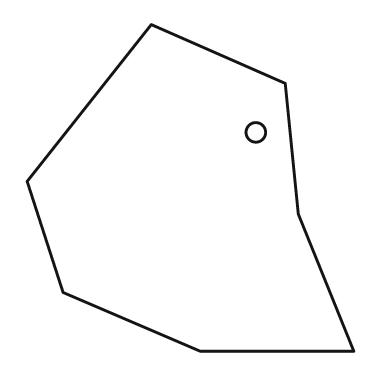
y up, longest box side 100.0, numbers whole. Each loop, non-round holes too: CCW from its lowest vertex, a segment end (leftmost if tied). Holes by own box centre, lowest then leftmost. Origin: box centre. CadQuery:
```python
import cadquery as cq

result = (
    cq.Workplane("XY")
    .moveTo(3.0, -50.0)
    .lineTo(50.0, -50.0)
    .lineTo(33.0, -8.0)
    .lineTo(29.0, 32.0)
    .lineTo(-12.0, 50.0)
    .lineTo(-50.0, 2.0)
    .lineTo(-39.0, -32.0)
    .close()
    .moveTo(20.0, 17.0)
    .circle(3.0)
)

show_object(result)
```